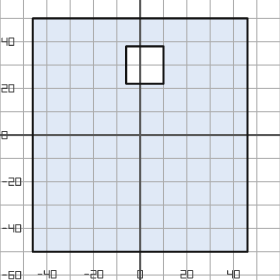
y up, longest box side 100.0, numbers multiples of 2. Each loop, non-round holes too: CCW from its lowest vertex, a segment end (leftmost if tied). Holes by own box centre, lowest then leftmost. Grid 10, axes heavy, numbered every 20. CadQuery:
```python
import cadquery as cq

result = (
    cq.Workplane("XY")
    .moveTo(-46.0, -50.0)
    .lineTo(46.0, -50.0)
    .lineTo(46.0, 50.0)
    .lineTo(-46.0, 50.0)
    .close()
    .moveTo(-6.0, 22.0)
    .lineTo(10.0, 22.0)
    .lineTo(10.0, 38.0)
    .lineTo(-6.0, 38.0)
    .close()
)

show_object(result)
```